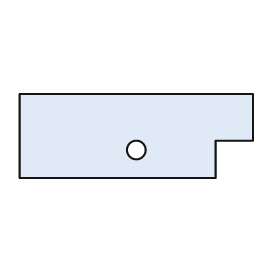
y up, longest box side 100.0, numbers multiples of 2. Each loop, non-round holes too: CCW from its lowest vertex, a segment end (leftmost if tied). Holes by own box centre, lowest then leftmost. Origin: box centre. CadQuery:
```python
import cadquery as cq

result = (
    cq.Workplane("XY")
    .moveTo(-50.0, -18.0)
    .lineTo(34.0, -18.0)
    .lineTo(34.0, -2.0)
    .lineTo(50.0, -2.0)
    .lineTo(50.0, 18.0)
    .lineTo(-50.0, 18.0)
    .close()
    .moveTo(0.0, -6.0)
    .circle(4.0)
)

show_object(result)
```